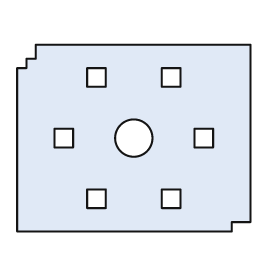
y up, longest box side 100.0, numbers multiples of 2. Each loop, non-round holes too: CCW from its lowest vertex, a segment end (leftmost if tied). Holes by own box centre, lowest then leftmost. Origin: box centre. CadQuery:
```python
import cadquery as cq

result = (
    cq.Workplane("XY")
    .moveTo(-50.0, -40.0)
    .lineTo(42.0, -40.0)
    .lineTo(42.0, -36.0)
    .lineTo(50.0, -36.0)
    .lineTo(50.0, 40.0)
    .lineTo(-42.0, 40.0)
    .lineTo(-42.0, 34.0)
    .lineTo(-46.0, 34.0)
    .lineTo(-46.0, 30.0)
    .lineTo(-50.0, 30.0)
    .close()
    .moveTo(-20.0, -30.0)
    .lineTo(-12.0, -30.0)
    .lineTo(-12.0, -22.0)
    .lineTo(-20.0, -22.0)
    .close()
    .moveTo(12.0, -30.0)
    .lineTo(20.0, -30.0)
    .lineTo(20.0, -22.0)
    .lineTo(12.0, -22.0)
    .close()
    .moveTo(-34.0, -4.0)
    .lineTo(-26.0, -4.0)
    .lineTo(-26.0, 4.0)
    .lineTo(-34.0, 4.0)
    .close()
    .moveTo(0.0, 0.0)
    .circle(8.0)
    .moveTo(26.0, -4.0)
    .lineTo(34.0, -4.0)
    .lineTo(34.0, 4.0)
    .lineTo(26.0, 4.0)
    .close()
    .moveTo(-20.0, 22.0)
    .lineTo(-12.0, 22.0)
    .lineTo(-12.0, 30.0)
    .lineTo(-20.0, 30.0)
    .close()
    .moveTo(12.0, 22.0)
    .lineTo(20.0, 22.0)
    .lineTo(20.0, 30.0)
    .lineTo(12.0, 30.0)
    .close()
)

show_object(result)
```